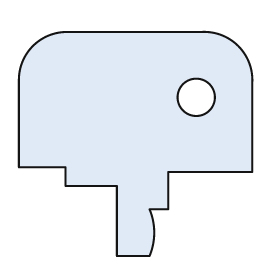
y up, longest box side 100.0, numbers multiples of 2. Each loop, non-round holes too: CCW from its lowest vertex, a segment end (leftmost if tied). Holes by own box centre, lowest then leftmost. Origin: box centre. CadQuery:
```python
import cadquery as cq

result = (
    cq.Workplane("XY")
    .moveTo(-8.0, -48.0)
    .lineTo(6.0, -48.0)
    .threePointArc((8.0, -38.0), (6.0, -28.0))
    .lineTo(14.0, -28.0)
    .lineTo(14.0, -12.0)
    .lineTo(50.0, -12.0)
    .lineTo(50.0, 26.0)
    .threePointArc((44.0, 42.0), (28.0, 48.0))
    .lineTo(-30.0, 48.0)
    .threePointArc((-44.0, 42.0), (-50.0, 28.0))
    .lineTo(-50.0, -10.0)
    .lineTo(-30.0, -10.0)
    .lineTo(-30.0, -18.0)
    .lineTo(-8.0, -18.0)
    .close()
    .moveTo(26.0, 20.0)
    .circle(8.0)
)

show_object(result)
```